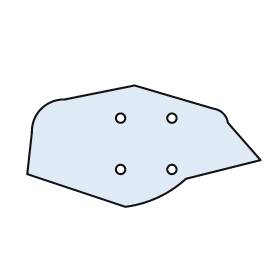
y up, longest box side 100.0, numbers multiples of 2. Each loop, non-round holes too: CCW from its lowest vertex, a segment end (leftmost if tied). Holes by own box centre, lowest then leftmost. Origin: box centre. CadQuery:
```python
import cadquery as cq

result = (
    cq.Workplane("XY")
    .moveTo(-8.0, -26.0)
    .threePointArc((6.0, -22.0), (18.0, -14.0))
    .lineTo(50.0, -6.0)
    .lineTo(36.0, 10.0)
    .threePointArc((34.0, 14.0), (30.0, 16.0))
    .lineTo(-4.0, 26.0)
    .lineTo(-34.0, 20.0)
    .threePointArc((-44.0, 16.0), (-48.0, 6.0))
    .lineTo(-50.0, -12.0)
    .close()
    .moveTo(-10.0, -10.0)
    .circle(2.0)
    .moveTo(12.0, -10.0)
    .circle(2.0)
    .moveTo(-10.0, 12.0)
    .circle(2.0)
    .moveTo(12.0, 12.0)
    .circle(2.0)
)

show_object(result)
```